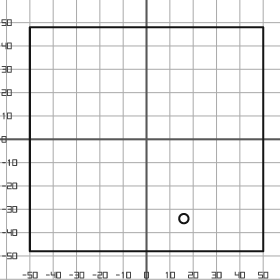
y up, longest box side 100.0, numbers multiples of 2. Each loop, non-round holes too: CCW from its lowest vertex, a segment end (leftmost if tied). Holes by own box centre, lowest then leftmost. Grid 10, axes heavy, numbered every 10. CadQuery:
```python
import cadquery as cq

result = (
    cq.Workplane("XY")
    .moveTo(-50.0, -48.0)
    .lineTo(50.0, -48.0)
    .lineTo(50.0, 48.0)
    .lineTo(-50.0, 48.0)
    .close()
    .moveTo(16.0, -34.0)
    .circle(2.0)
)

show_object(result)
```